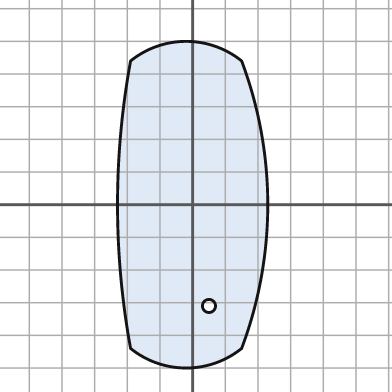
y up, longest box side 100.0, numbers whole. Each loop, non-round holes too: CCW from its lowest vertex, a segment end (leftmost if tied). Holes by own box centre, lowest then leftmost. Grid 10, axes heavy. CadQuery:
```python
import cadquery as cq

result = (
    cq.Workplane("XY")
    .moveTo(-19.0, -44.0)
    .threePointArc((-2.0, -50.0), (15.0, -44.0))
    .threePointArc((23.0, 0.0), (15.0, 44.0))
    .threePointArc((-2.0, 50.0), (-19.0, 44.0))
    .threePointArc((-23.0, 0.0), (-19.0, -44.0))
    .close()
    .moveTo(5.0, -31.0)
    .circle(2.0)
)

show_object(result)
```